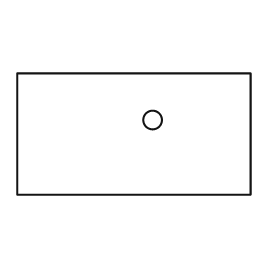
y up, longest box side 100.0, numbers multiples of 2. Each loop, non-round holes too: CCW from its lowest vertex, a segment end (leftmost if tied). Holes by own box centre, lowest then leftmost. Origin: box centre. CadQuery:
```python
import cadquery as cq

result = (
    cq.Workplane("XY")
    .moveTo(-50.0, -26.0)
    .lineTo(50.0, -26.0)
    .lineTo(50.0, 26.0)
    .lineTo(-50.0, 26.0)
    .close()
    .moveTo(8.0, 6.0)
    .circle(4.0)
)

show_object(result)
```